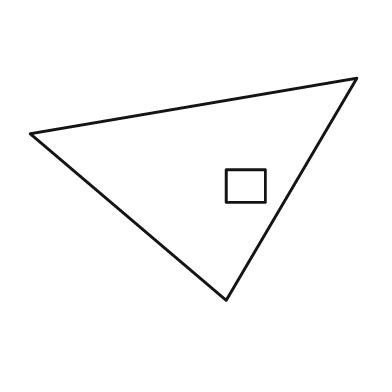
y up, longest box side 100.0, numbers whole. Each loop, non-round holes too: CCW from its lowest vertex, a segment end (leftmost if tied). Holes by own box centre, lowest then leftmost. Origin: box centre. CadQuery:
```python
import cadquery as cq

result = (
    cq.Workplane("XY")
    .moveTo(10.0, -34.0)
    .lineTo(50.0, 34.0)
    .lineTo(-50.0, 17.0)
    .close()
    .moveTo(10.0, -4.0)
    .lineTo(22.0, -4.0)
    .lineTo(22.0, 6.0)
    .lineTo(10.0, 6.0)
    .close()
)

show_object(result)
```